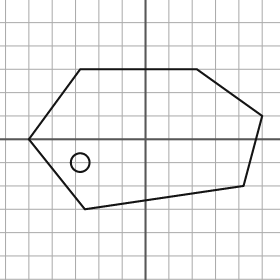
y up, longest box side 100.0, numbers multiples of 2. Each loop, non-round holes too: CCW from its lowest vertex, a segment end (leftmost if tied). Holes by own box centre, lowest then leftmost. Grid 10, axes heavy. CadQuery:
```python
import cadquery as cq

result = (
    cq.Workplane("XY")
    .moveTo(-26.0, -30.0)
    .lineTo(42.0, -20.0)
    .lineTo(50.0, 10.0)
    .lineTo(22.0, 30.0)
    .lineTo(-28.0, 30.0)
    .lineTo(-50.0, 0.0)
    .close()
    .moveTo(-28.0, -10.0)
    .circle(4.0)
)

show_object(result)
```